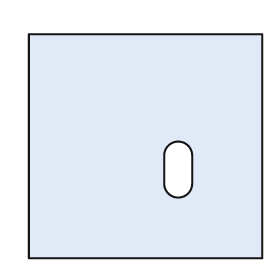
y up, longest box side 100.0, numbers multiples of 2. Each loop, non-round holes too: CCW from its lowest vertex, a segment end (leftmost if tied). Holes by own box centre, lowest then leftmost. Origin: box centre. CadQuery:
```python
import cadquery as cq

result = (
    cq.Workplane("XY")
    .moveTo(-50.0, -48.0)
    .lineTo(50.0, -48.0)
    .lineTo(50.0, 48.0)
    .lineTo(-50.0, 48.0)
    .close()
    .moveTo(8.0, -16.0)
    .threePointArc((14.0, -22.0), (20.0, -16.0))
    .lineTo(20.0, -4.0)
    .threePointArc((14.0, 2.0), (8.0, -4.0))
    .close()
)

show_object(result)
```